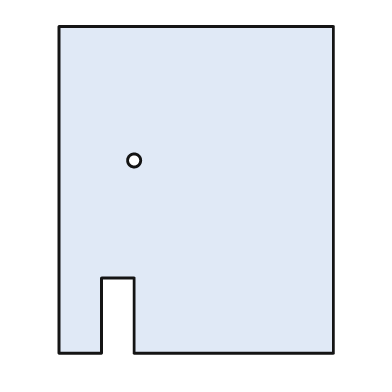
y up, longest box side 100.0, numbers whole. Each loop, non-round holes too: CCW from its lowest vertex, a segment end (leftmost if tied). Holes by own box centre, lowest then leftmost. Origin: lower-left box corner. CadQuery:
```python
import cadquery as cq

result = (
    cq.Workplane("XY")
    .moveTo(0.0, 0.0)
    .lineTo(13.0, 0.0)
    .lineTo(13.0, 23.0)
    .lineTo(23.0, 23.0)
    .lineTo(23.0, 0.0)
    .lineTo(84.0, 0.0)
    .lineTo(84.0, 100.0)
    .lineTo(0.0, 100.0)
    .close()
    .moveTo(23.0, 59.0)
    .circle(2.0)
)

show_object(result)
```